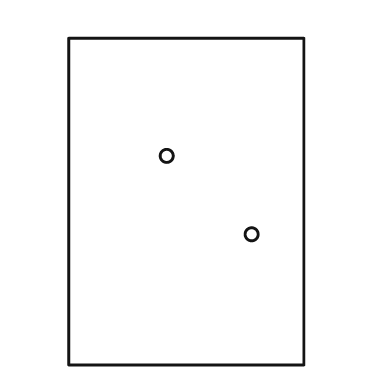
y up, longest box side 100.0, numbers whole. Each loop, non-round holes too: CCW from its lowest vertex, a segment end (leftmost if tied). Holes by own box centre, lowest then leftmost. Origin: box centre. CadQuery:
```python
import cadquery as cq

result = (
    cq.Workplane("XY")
    .moveTo(-36.0, -50.0)
    .lineTo(36.0, -50.0)
    .lineTo(36.0, 50.0)
    .lineTo(-36.0, 50.0)
    .close()
    .moveTo(20.0, -10.0)
    .circle(2.0)
    .moveTo(-6.0, 14.0)
    .circle(2.0)
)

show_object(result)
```